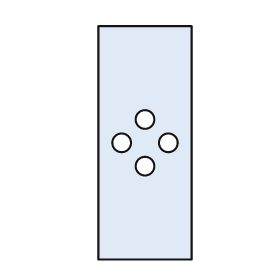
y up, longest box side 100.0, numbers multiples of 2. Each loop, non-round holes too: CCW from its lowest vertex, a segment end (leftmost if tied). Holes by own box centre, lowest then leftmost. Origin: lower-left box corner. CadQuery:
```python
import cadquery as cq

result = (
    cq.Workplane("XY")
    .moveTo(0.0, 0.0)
    .lineTo(40.0, 0.0)
    .lineTo(40.0, 100.0)
    .lineTo(0.0, 100.0)
    .close()
    .moveTo(20.0, 40.0)
    .circle(4.0)
    .moveTo(10.0, 50.0)
    .circle(4.0)
    .moveTo(30.0, 50.0)
    .circle(4.0)
    .moveTo(20.0, 60.0)
    .circle(4.0)
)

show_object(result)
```